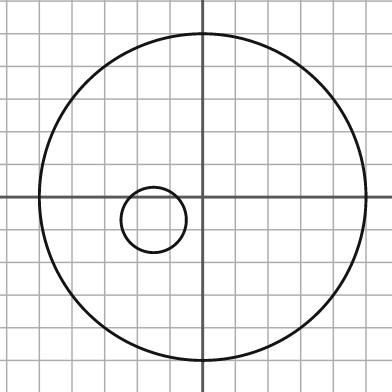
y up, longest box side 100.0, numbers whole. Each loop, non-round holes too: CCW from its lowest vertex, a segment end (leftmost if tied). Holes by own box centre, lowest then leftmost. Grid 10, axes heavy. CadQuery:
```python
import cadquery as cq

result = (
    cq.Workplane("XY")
    .moveTo(0.0, 0.0)
    .circle(50.0)
    .moveTo(-15.0, -7.0)
    .circle(10.0)
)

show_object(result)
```